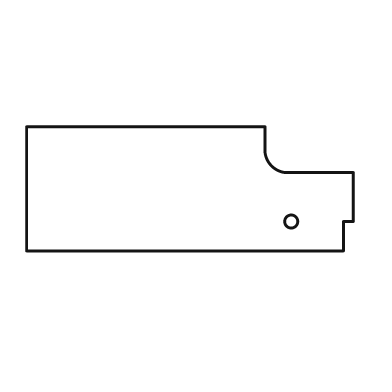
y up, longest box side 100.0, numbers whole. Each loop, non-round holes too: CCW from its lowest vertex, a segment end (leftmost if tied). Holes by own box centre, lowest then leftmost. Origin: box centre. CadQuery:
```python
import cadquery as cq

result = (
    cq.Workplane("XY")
    .moveTo(-50.0, -19.0)
    .lineTo(47.0, -19.0)
    .lineTo(47.0, -10.0)
    .lineTo(50.0, -10.0)
    .lineTo(50.0, 5.0)
    .lineTo(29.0, 5.0)
    .threePointArc((25.0, 7.0), (23.0, 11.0))
    .lineTo(23.0, 19.0)
    .lineTo(-50.0, 19.0)
    .close()
    .moveTo(31.0, -10.0)
    .circle(2.0)
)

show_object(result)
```